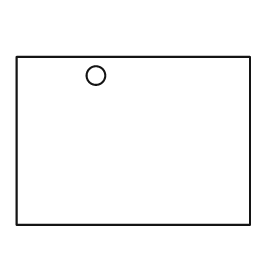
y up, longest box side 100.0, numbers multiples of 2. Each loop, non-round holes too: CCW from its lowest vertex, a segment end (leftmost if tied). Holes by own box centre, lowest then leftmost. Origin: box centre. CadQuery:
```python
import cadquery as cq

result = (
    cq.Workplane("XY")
    .moveTo(-50.0, -36.0)
    .lineTo(50.0, -36.0)
    .lineTo(50.0, 36.0)
    .lineTo(-50.0, 36.0)
    .close()
    .moveTo(-16.0, 28.0)
    .circle(4.0)
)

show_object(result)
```